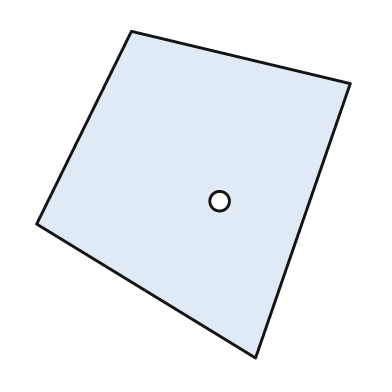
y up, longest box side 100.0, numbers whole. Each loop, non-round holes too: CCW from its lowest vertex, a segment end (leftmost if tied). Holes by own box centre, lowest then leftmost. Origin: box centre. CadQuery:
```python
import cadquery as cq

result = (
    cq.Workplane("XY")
    .moveTo(19.0, -50.0)
    .lineTo(48.0, 34.0)
    .lineTo(-19.0, 50.0)
    .lineTo(-48.0, -9.0)
    .close()
    .moveTo(8.0, -2.0)
    .circle(3.0)
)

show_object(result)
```